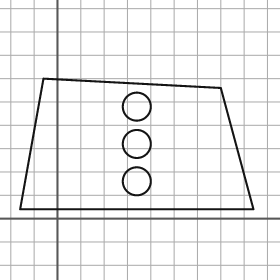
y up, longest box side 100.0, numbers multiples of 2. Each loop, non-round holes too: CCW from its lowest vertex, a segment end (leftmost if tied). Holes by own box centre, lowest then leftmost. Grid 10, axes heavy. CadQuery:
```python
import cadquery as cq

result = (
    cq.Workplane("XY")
    .moveTo(-16.0, 4.0)
    .lineTo(84.0, 4.0)
    .lineTo(70.0, 56.0)
    .lineTo(-6.0, 60.0)
    .close()
    .moveTo(34.0, 16.0)
    .circle(6.0)
    .moveTo(34.0, 32.0)
    .circle(6.0)
    .moveTo(34.0, 48.0)
    .circle(6.0)
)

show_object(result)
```